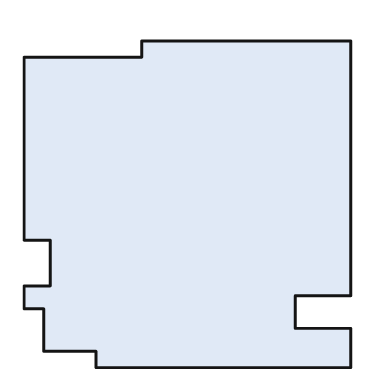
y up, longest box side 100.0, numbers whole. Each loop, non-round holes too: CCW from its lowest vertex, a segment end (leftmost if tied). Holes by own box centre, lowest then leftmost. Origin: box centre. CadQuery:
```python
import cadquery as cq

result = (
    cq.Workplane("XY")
    .moveTo(-28.0, -50.0)
    .lineTo(50.0, -50.0)
    .lineTo(50.0, -38.0)
    .lineTo(33.0, -38.0)
    .lineTo(33.0, -28.0)
    .lineTo(50.0, -28.0)
    .lineTo(50.0, 50.0)
    .lineTo(-14.0, 50.0)
    .lineTo(-14.0, 45.0)
    .lineTo(-50.0, 45.0)
    .lineTo(-50.0, -11.0)
    .lineTo(-42.0, -11.0)
    .lineTo(-42.0, -25.0)
    .lineTo(-50.0, -25.0)
    .lineTo(-50.0, -32.0)
    .lineTo(-44.0, -32.0)
    .lineTo(-44.0, -45.0)
    .lineTo(-28.0, -45.0)
    .close()
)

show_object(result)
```